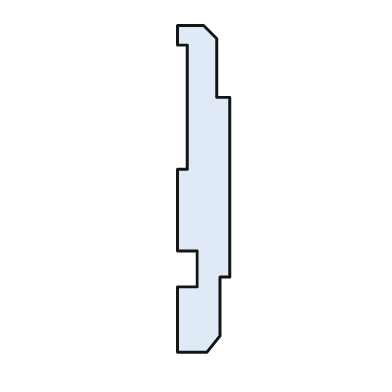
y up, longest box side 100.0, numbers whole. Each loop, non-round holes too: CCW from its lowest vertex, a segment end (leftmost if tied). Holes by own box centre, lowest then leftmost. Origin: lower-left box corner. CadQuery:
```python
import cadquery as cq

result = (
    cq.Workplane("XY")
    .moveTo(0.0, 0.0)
    .lineTo(9.0, 0.0)
    .lineTo(13.0, 5.0)
    .lineTo(13.0, 23.0)
    .lineTo(16.0, 23.0)
    .lineTo(16.0, 78.0)
    .lineTo(12.0, 78.0)
    .lineTo(12.0, 96.0)
    .lineTo(8.0, 100.0)
    .lineTo(0.0, 100.0)
    .lineTo(0.0, 94.0)
    .lineTo(3.0, 94.0)
    .lineTo(3.0, 56.0)
    .lineTo(0.0, 56.0)
    .lineTo(0.0, 31.0)
    .lineTo(6.0, 31.0)
    .lineTo(6.0, 20.0)
    .lineTo(0.0, 20.0)
    .close()
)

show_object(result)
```